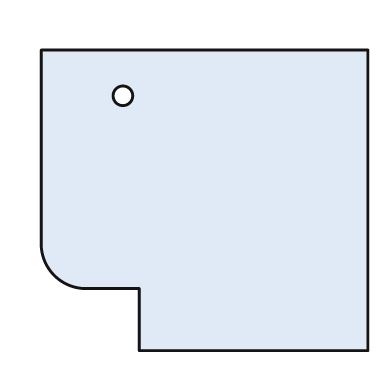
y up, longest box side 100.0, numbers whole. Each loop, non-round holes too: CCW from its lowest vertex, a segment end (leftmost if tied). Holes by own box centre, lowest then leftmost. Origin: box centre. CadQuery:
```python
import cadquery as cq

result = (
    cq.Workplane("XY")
    .moveTo(-20.0, -46.0)
    .lineTo(50.0, -46.0)
    .lineTo(50.0, 46.0)
    .lineTo(-50.0, 46.0)
    .lineTo(-50.0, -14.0)
    .threePointArc((-46.0, -23.0), (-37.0, -27.0))
    .lineTo(-20.0, -27.0)
    .close()
    .moveTo(-25.0, 32.0)
    .circle(3.0)
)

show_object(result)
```